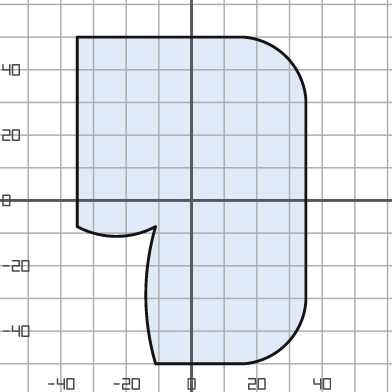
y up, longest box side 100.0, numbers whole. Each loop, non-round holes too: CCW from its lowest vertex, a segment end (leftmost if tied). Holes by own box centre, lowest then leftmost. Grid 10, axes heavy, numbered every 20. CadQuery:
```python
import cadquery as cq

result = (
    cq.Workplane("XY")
    .moveTo(-11.0, -50.0)
    .lineTo(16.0, -50.0)
    .threePointArc((29.0, -44.0), (35.0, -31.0))
    .lineTo(35.0, 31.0)
    .threePointArc((29.0, 44.0), (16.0, 50.0))
    .lineTo(-35.0, 50.0)
    .lineTo(-35.0, -8.0)
    .threePointArc((-23.0, -11.0), (-11.0, -8.0))
    .threePointArc((-14.0, -29.0), (-11.0, -50.0))
    .close()
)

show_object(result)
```